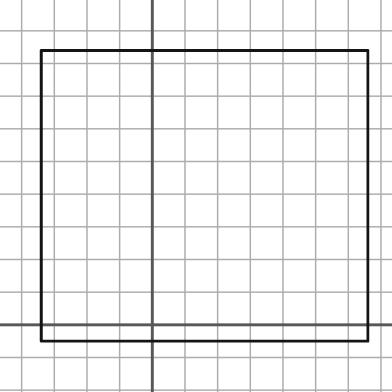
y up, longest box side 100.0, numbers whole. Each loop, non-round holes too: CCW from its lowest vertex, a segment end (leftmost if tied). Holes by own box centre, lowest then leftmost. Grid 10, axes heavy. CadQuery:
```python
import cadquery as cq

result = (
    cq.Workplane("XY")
    .moveTo(-34.0, -5.0)
    .lineTo(66.0, -5.0)
    .lineTo(66.0, 84.0)
    .lineTo(-34.0, 84.0)
    .close()
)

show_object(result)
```